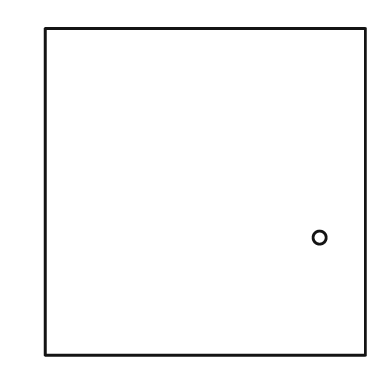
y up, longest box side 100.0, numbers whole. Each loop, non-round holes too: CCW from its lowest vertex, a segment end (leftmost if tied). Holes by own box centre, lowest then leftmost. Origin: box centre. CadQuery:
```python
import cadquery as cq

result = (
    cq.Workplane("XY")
    .moveTo(-49.0, -50.0)
    .lineTo(49.0, -50.0)
    .lineTo(49.0, 50.0)
    .lineTo(-49.0, 50.0)
    .close()
    .moveTo(35.0, -14.0)
    .circle(2.0)
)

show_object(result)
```